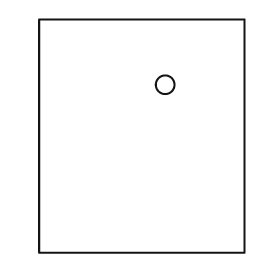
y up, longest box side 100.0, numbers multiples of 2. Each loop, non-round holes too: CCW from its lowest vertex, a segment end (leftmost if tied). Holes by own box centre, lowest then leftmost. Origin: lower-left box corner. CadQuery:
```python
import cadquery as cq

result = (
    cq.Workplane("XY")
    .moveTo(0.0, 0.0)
    .lineTo(88.0, 0.0)
    .lineTo(88.0, 100.0)
    .lineTo(0.0, 100.0)
    .close()
    .moveTo(54.0, 72.0)
    .circle(4.0)
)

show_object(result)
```